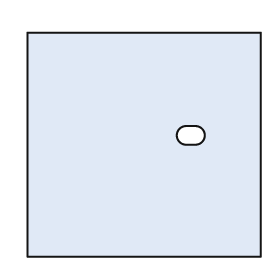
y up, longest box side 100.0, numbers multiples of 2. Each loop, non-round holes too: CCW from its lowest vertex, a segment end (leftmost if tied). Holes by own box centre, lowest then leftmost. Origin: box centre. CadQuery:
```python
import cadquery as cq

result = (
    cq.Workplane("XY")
    .moveTo(-50.0, -48.0)
    .lineTo(50.0, -48.0)
    .lineTo(50.0, 48.0)
    .lineTo(-50.0, 48.0)
    .close()
    .moveTo(18.0, 0.0)
    .lineTo(22.0, 0.0)
    .threePointArc((26.0, 4.0), (22.0, 8.0))
    .lineTo(18.0, 8.0)
    .threePointArc((14.0, 4.0), (18.0, 0.0))
    .close()
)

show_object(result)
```